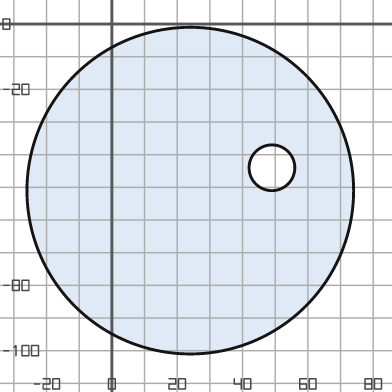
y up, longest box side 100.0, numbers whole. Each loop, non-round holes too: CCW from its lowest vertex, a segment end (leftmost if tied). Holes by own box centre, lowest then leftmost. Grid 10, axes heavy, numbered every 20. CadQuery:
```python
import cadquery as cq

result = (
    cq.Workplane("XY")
    .moveTo(24.0, -51.0)
    .circle(50.0)
    .moveTo(49.0, -44.0)
    .circle(7.0)
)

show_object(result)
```